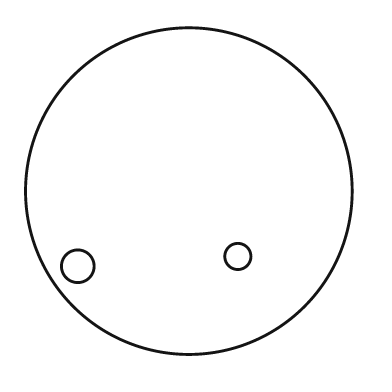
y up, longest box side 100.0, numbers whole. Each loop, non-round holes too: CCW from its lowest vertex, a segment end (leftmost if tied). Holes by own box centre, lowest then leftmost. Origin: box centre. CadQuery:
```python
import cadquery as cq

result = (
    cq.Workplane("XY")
    .moveTo(0.0, 0.0)
    .circle(50.0)
    .moveTo(-34.0, -23.0)
    .circle(5.0)
    .moveTo(15.0, -20.0)
    .circle(4.0)
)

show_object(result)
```